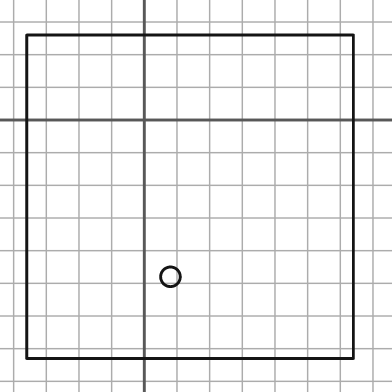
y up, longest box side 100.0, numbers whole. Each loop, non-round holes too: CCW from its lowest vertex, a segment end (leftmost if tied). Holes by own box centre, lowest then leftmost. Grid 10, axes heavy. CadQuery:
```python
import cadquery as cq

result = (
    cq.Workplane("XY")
    .moveTo(-36.0, -73.0)
    .lineTo(64.0, -73.0)
    .lineTo(64.0, 26.0)
    .lineTo(-36.0, 26.0)
    .close()
    .moveTo(8.0, -48.0)
    .circle(3.0)
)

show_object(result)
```